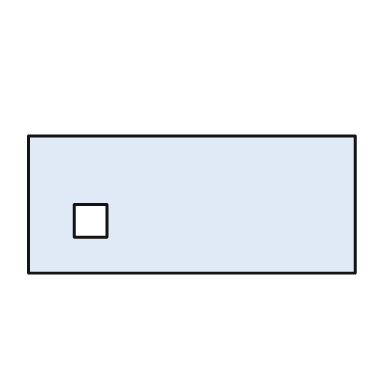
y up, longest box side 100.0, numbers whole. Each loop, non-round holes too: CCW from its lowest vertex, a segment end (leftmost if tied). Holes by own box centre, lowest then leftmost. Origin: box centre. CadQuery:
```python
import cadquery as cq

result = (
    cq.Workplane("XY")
    .moveTo(-50.0, -21.0)
    .lineTo(50.0, -21.0)
    .lineTo(50.0, 21.0)
    .lineTo(-50.0, 21.0)
    .close()
    .moveTo(-36.0, -10.0)
    .lineTo(-26.0, -10.0)
    .lineTo(-26.0, 0.0)
    .lineTo(-36.0, 0.0)
    .close()
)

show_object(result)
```